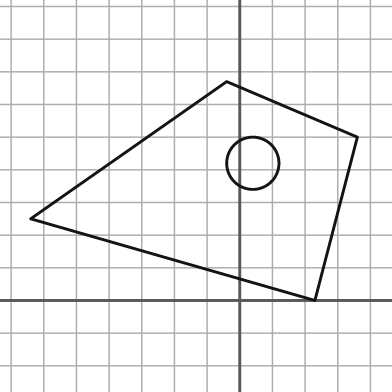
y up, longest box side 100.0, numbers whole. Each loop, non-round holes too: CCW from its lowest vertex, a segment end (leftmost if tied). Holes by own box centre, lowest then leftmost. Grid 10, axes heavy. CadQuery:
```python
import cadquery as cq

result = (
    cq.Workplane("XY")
    .moveTo(23.0, 0.0)
    .lineTo(36.0, 50.0)
    .lineTo(-4.0, 67.0)
    .lineTo(-64.0, 25.0)
    .close()
    .moveTo(4.0, 42.0)
    .circle(8.0)
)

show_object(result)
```